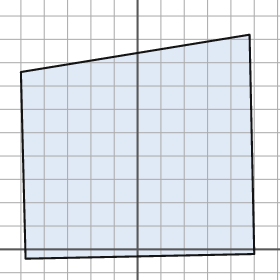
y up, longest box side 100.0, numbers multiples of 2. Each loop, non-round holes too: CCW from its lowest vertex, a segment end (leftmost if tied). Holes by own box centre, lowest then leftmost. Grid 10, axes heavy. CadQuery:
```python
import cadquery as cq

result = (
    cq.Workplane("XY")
    .moveTo(-48.0, -4.0)
    .lineTo(50.0, -2.0)
    .lineTo(48.0, 92.0)
    .lineTo(-50.0, 76.0)
    .close()
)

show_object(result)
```